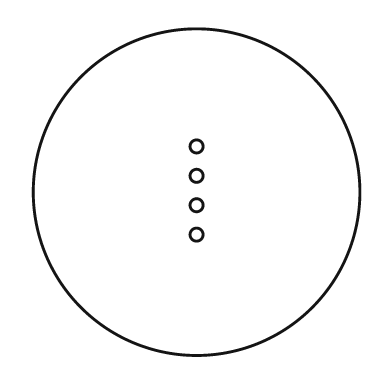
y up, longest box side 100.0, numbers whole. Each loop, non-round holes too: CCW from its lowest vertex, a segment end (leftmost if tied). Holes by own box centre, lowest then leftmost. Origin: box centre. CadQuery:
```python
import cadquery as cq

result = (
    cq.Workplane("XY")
    .moveTo(0.0, 0.0)
    .circle(50.0)
    .moveTo(0.0, -13.0)
    .circle(2.0)
    .moveTo(0.0, -4.0)
    .circle(2.0)
    .moveTo(0.0, 5.0)
    .circle(2.0)
    .moveTo(0.0, 14.0)
    .circle(2.0)
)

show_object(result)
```